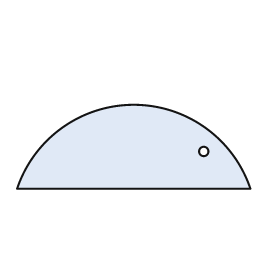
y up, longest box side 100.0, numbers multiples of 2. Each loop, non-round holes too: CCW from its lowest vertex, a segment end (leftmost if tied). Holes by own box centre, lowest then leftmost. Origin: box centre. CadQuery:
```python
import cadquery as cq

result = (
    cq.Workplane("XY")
    .moveTo(-50.0, -18.0)
    .lineTo(50.0, -18.0)
    .threePointArc((0.0, 18.0), (-50.0, -18.0))
    .close()
    .moveTo(30.0, -2.0)
    .circle(2.0)
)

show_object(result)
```